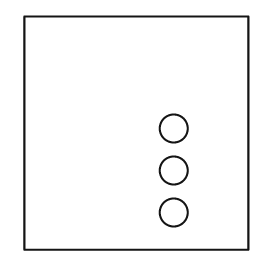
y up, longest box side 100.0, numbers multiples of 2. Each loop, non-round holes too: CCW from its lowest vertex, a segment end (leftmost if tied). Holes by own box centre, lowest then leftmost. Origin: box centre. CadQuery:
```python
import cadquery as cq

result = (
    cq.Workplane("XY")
    .moveTo(-48.0, -50.0)
    .lineTo(48.0, -50.0)
    .lineTo(48.0, 50.0)
    .lineTo(-48.0, 50.0)
    .close()
    .moveTo(16.0, -34.0)
    .circle(6.0)
    .moveTo(16.0, -16.0)
    .circle(6.0)
    .moveTo(16.0, 2.0)
    .circle(6.0)
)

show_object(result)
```